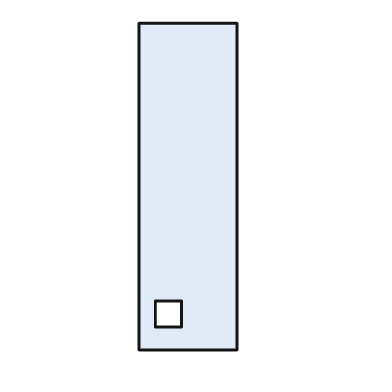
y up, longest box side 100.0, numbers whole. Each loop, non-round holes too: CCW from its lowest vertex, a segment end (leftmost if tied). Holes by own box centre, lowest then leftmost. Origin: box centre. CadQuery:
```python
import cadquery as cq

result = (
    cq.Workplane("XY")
    .moveTo(-15.0, -50.0)
    .lineTo(15.0, -50.0)
    .lineTo(15.0, 50.0)
    .lineTo(-15.0, 50.0)
    .close()
    .moveTo(-10.0, -43.0)
    .lineTo(-2.0, -43.0)
    .lineTo(-2.0, -35.0)
    .lineTo(-10.0, -35.0)
    .close()
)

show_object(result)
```